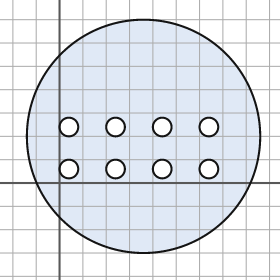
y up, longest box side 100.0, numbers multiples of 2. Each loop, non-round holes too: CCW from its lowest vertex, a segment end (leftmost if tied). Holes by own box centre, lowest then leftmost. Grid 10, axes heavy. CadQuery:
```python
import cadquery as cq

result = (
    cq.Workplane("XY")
    .moveTo(36.0, 20.0)
    .circle(50.0)
    .moveTo(4.0, 6.0)
    .circle(4.0)
    .moveTo(24.0, 6.0)
    .circle(4.0)
    .moveTo(44.0, 6.0)
    .circle(4.0)
    .moveTo(64.0, 6.0)
    .circle(4.0)
    .moveTo(4.0, 24.0)
    .circle(4.0)
    .moveTo(24.0, 24.0)
    .circle(4.0)
    .moveTo(44.0, 24.0)
    .circle(4.0)
    .moveTo(64.0, 24.0)
    .circle(4.0)
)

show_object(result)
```